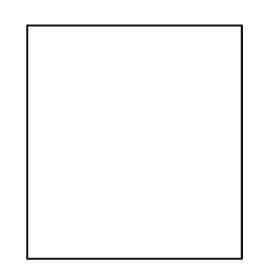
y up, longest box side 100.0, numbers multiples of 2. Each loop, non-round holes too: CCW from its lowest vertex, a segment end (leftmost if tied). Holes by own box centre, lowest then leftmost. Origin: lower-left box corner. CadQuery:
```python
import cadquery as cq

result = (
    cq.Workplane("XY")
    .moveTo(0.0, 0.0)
    .lineTo(92.0, 0.0)
    .lineTo(92.0, 100.0)
    .lineTo(0.0, 100.0)
    .close()
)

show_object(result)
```